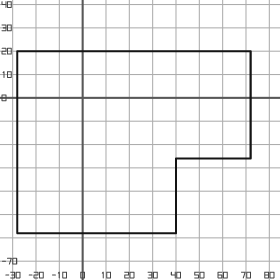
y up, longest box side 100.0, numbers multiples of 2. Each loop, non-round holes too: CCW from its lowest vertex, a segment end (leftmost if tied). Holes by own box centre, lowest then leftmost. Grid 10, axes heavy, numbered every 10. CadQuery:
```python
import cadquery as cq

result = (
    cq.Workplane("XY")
    .moveTo(-28.0, -58.0)
    .lineTo(40.0, -58.0)
    .lineTo(40.0, -26.0)
    .lineTo(72.0, -26.0)
    .lineTo(72.0, 20.0)
    .lineTo(-28.0, 20.0)
    .close()
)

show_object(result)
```